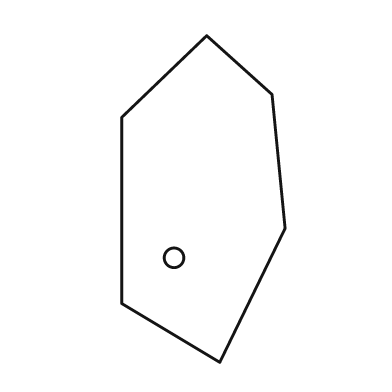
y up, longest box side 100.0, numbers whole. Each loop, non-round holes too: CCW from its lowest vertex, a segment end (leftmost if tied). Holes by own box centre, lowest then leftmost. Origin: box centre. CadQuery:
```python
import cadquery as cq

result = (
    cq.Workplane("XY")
    .moveTo(5.0, -50.0)
    .lineTo(25.0, -9.0)
    .lineTo(21.0, 32.0)
    .lineTo(1.0, 50.0)
    .lineTo(-25.0, 25.0)
    .lineTo(-25.0, -32.0)
    .close()
    .moveTo(-9.0, -18.0)
    .circle(3.0)
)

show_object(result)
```